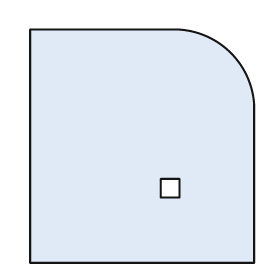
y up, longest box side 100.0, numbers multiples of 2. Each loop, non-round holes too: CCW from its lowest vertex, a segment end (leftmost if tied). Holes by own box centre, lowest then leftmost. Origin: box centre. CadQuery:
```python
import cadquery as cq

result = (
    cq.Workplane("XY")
    .moveTo(-48.0, -50.0)
    .lineTo(48.0, -50.0)
    .lineTo(48.0, 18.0)
    .threePointArc((38.0, 40.0), (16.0, 50.0))
    .lineTo(-48.0, 50.0)
    .close()
    .moveTo(8.0, -22.0)
    .lineTo(16.0, -22.0)
    .lineTo(16.0, -14.0)
    .lineTo(8.0, -14.0)
    .close()
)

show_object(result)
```